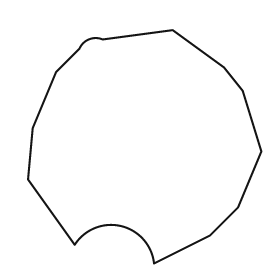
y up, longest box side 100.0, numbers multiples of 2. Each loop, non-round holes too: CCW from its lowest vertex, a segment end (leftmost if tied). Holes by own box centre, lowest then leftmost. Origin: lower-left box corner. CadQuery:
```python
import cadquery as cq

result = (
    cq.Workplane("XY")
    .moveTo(54.0, 0.0)
    .lineTo(78.0, 12.0)
    .lineTo(90.0, 24.0)
    .lineTo(100.0, 48.0)
    .lineTo(92.0, 74.0)
    .lineTo(84.0, 84.0)
    .lineTo(62.0, 100.0)
    .lineTo(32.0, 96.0)
    .threePointArc((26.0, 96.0), (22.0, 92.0))
    .lineTo(12.0, 82.0)
    .lineTo(2.0, 58.0)
    .lineTo(0.0, 36.0)
    .lineTo(20.0, 8.0)
    .threePointArc((40.0, 16.0), (54.0, 0.0))
    .close()
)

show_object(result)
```